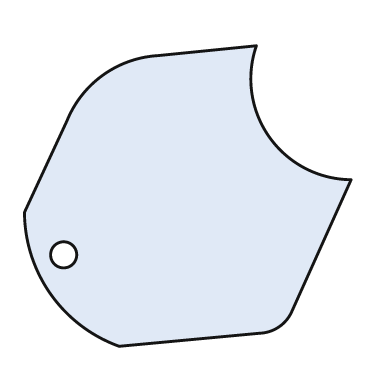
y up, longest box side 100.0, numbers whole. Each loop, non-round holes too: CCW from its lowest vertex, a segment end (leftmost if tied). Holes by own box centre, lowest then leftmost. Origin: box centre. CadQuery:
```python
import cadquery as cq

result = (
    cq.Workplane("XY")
    .moveTo(-21.0, -46.0)
    .lineTo(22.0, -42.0)
    .threePointArc((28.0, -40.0), (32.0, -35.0))
    .lineTo(50.0, 5.0)
    .threePointArc((25.0, 18.0), (21.0, 46.0))
    .lineTo(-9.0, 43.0)
    .threePointArc((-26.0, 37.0), (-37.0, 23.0))
    .lineTo(-50.0, -5.0)
    .threePointArc((-42.0, -30.0), (-21.0, -46.0))
    .close()
    .moveTo(-38.0, -18.0)
    .circle(4.0)
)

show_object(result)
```